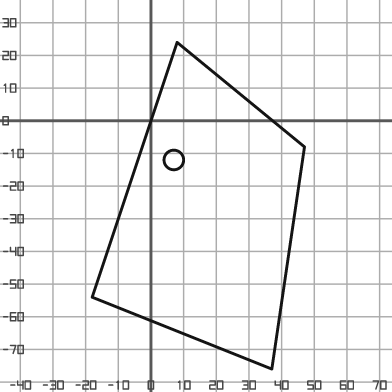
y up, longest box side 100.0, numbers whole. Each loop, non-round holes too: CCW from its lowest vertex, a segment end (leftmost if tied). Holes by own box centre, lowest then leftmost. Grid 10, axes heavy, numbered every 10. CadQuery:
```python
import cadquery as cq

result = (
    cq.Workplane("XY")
    .moveTo(37.0, -76.0)
    .lineTo(47.0, -8.0)
    .lineTo(8.0, 24.0)
    .lineTo(-18.0, -54.0)
    .close()
    .moveTo(7.0, -12.0)
    .circle(3.0)
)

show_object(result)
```